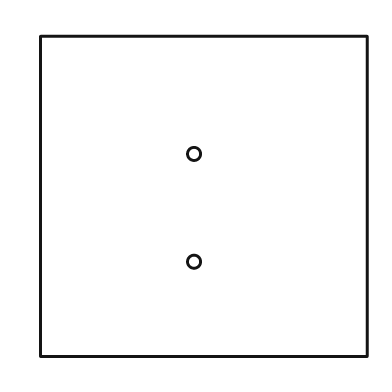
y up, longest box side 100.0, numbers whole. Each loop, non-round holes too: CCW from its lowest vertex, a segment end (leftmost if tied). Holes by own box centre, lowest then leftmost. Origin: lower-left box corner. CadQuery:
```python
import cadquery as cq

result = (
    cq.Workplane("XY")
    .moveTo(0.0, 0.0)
    .lineTo(100.0, 0.0)
    .lineTo(100.0, 98.0)
    .lineTo(0.0, 98.0)
    .close()
    .moveTo(47.0, 29.0)
    .circle(2.0)
    .moveTo(47.0, 62.0)
    .circle(2.0)
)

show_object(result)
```